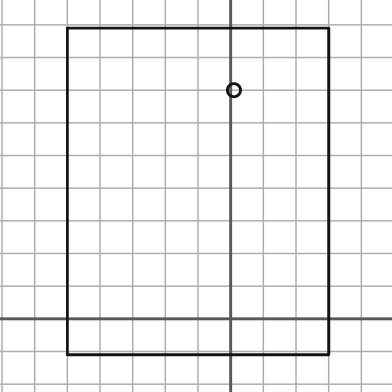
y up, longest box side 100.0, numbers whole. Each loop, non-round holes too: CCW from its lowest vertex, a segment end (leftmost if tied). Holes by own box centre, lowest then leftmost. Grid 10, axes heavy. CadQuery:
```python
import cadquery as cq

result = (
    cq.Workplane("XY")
    .moveTo(-50.0, -11.0)
    .lineTo(30.0, -11.0)
    .lineTo(30.0, 89.0)
    .lineTo(-50.0, 89.0)
    .close()
    .moveTo(1.0, 70.0)
    .circle(2.0)
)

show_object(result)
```